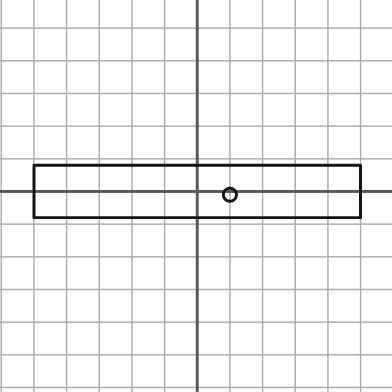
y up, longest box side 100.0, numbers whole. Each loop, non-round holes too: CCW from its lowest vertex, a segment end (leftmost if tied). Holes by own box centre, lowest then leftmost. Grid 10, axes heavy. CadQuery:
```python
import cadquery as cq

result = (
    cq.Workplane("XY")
    .moveTo(-50.0, -8.0)
    .lineTo(50.0, -8.0)
    .lineTo(50.0, 8.0)
    .lineTo(-50.0, 8.0)
    .close()
    .moveTo(10.0, -1.0)
    .circle(2.0)
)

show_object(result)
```